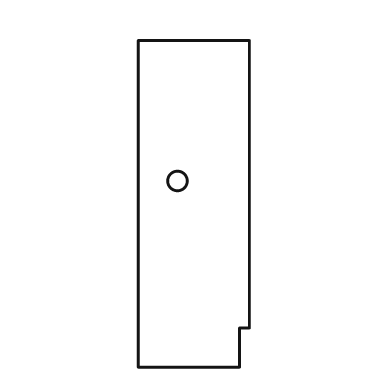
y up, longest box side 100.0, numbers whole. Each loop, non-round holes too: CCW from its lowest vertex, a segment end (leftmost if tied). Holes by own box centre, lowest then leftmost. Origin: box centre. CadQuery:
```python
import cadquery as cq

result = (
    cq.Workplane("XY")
    .moveTo(-17.0, -50.0)
    .lineTo(14.0, -50.0)
    .lineTo(14.0, -38.0)
    .lineTo(17.0, -38.0)
    .lineTo(17.0, 50.0)
    .lineTo(-17.0, 50.0)
    .close()
    .moveTo(-5.0, 7.0)
    .circle(3.0)
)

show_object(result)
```